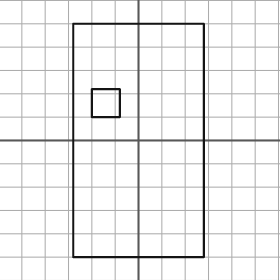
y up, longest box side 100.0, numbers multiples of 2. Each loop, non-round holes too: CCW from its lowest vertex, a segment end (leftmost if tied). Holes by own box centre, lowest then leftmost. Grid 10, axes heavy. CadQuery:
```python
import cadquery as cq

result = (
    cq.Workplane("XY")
    .moveTo(-28.0, -50.0)
    .lineTo(28.0, -50.0)
    .lineTo(28.0, 50.0)
    .lineTo(-28.0, 50.0)
    .close()
    .moveTo(-20.0, 10.0)
    .lineTo(-8.0, 10.0)
    .lineTo(-8.0, 22.0)
    .lineTo(-20.0, 22.0)
    .close()
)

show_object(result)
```